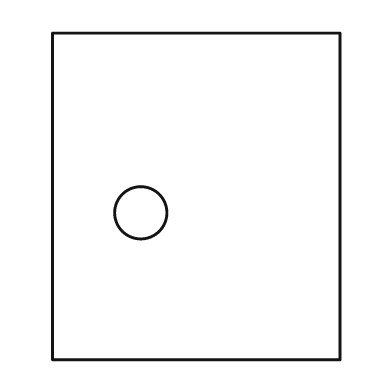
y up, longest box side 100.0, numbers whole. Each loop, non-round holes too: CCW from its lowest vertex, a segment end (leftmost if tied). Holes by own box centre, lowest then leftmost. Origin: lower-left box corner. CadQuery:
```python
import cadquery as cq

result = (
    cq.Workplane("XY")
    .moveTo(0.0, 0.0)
    .lineTo(88.0, 0.0)
    .lineTo(88.0, 100.0)
    .lineTo(0.0, 100.0)
    .close()
    .moveTo(27.0, 45.0)
    .circle(8.0)
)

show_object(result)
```